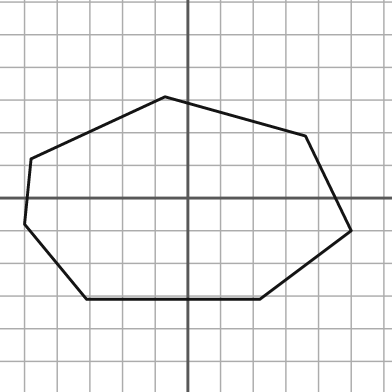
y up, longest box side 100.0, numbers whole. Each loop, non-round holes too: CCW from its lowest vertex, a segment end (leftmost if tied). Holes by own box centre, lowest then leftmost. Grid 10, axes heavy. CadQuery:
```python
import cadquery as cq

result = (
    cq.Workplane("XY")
    .moveTo(-31.0, -31.0)
    .lineTo(22.0, -31.0)
    .lineTo(50.0, -10.0)
    .lineTo(36.0, 19.0)
    .lineTo(-7.0, 31.0)
    .lineTo(-48.0, 12.0)
    .lineTo(-50.0, -8.0)
    .close()
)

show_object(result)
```